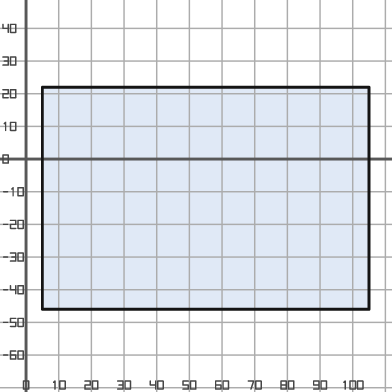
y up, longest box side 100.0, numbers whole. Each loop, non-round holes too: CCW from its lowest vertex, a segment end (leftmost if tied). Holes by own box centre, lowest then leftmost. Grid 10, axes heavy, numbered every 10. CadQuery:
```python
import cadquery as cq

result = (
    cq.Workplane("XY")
    .moveTo(5.0, -46.0)
    .lineTo(105.0, -46.0)
    .lineTo(105.0, 22.0)
    .lineTo(5.0, 22.0)
    .close()
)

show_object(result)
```